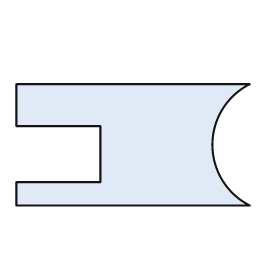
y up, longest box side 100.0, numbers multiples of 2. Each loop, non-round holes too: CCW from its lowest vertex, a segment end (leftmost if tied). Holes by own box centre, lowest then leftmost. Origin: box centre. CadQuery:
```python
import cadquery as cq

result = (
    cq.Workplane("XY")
    .moveTo(-50.0, -26.0)
    .lineTo(50.0, -26.0)
    .threePointArc((34.0, 0.0), (50.0, 26.0))
    .lineTo(-50.0, 26.0)
    .lineTo(-50.0, 8.0)
    .lineTo(-14.0, 8.0)
    .lineTo(-14.0, -16.0)
    .lineTo(-50.0, -16.0)
    .close()
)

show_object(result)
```